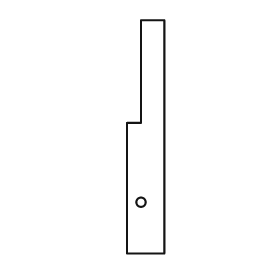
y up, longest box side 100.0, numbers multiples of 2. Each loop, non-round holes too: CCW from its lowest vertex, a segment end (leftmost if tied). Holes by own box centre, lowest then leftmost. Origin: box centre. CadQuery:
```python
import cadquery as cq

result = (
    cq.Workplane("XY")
    .moveTo(-8.0, -50.0)
    .lineTo(8.0, -50.0)
    .lineTo(8.0, 50.0)
    .lineTo(-2.0, 50.0)
    .lineTo(-2.0, 6.0)
    .lineTo(-8.0, 6.0)
    .close()
    .moveTo(-2.0, -28.0)
    .circle(2.0)
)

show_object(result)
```